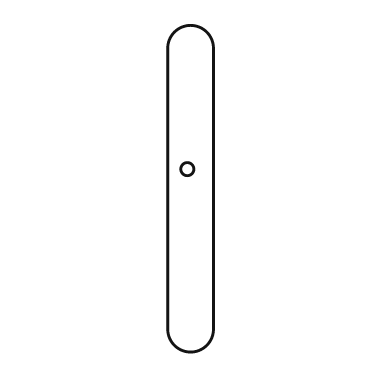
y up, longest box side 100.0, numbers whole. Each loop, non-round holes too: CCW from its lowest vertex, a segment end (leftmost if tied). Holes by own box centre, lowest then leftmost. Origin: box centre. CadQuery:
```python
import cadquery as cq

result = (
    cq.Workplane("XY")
    .moveTo(-7.0, -43.0)
    .threePointArc((0.0, -50.0), (7.0, -43.0))
    .lineTo(7.0, 43.0)
    .threePointArc((0.0, 50.0), (-7.0, 43.0))
    .close()
    .moveTo(-1.0, 6.0)
    .circle(2.0)
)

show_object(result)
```